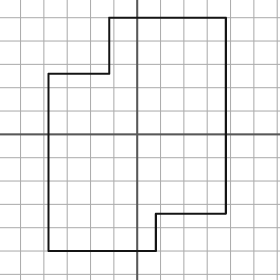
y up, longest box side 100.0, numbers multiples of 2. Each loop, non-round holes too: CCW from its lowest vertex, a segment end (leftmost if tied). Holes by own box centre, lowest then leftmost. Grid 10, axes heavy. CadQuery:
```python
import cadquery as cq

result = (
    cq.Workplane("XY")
    .moveTo(-38.0, -50.0)
    .lineTo(8.0, -50.0)
    .lineTo(8.0, -34.0)
    .lineTo(38.0, -34.0)
    .lineTo(38.0, 50.0)
    .lineTo(-12.0, 50.0)
    .lineTo(-12.0, 26.0)
    .lineTo(-38.0, 26.0)
    .close()
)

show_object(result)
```